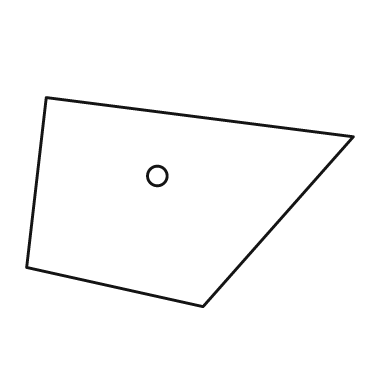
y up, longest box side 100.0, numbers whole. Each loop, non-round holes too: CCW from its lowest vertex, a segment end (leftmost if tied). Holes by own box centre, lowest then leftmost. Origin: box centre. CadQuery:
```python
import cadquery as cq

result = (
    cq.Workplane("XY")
    .moveTo(4.0, -32.0)
    .lineTo(50.0, 20.0)
    .lineTo(-44.0, 32.0)
    .lineTo(-50.0, -20.0)
    .close()
    .moveTo(-10.0, 8.0)
    .circle(3.0)
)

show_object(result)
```